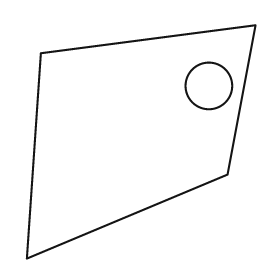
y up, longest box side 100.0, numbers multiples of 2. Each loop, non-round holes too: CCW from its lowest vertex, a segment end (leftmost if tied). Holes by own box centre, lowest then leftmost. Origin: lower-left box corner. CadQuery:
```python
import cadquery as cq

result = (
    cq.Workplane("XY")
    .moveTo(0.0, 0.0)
    .lineTo(86.0, 36.0)
    .lineTo(98.0, 100.0)
    .lineTo(6.0, 88.0)
    .close()
    .moveTo(78.0, 74.0)
    .circle(10.0)
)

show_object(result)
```